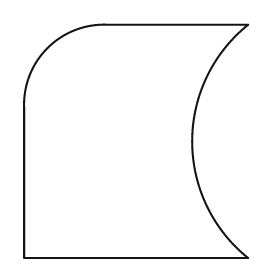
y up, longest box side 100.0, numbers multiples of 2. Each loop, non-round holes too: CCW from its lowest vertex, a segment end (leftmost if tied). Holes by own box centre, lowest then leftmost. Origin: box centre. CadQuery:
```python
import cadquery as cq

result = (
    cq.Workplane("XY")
    .moveTo(-48.0, -50.0)
    .lineTo(48.0, -50.0)
    .threePointArc((24.0, 0.0), (48.0, 50.0))
    .lineTo(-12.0, 50.0)
    .threePointArc((-38.0, 40.0), (-48.0, 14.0))
    .close()
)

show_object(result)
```